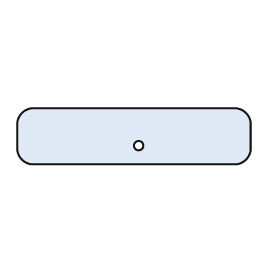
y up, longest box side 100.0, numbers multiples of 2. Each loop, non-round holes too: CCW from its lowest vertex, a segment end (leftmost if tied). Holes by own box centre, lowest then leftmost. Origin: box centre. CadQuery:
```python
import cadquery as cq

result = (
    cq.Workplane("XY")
    .moveTo(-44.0, -12.0)
    .lineTo(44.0, -12.0)
    .threePointArc((48.0, -10.0), (50.0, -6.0))
    .lineTo(50.0, 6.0)
    .threePointArc((48.0, 10.0), (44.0, 12.0))
    .lineTo(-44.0, 12.0)
    .threePointArc((-48.0, 10.0), (-50.0, 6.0))
    .lineTo(-50.0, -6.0)
    .threePointArc((-48.0, -10.0), (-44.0, -12.0))
    .close()
    .moveTo(2.0, -4.0)
    .circle(2.0)
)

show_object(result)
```